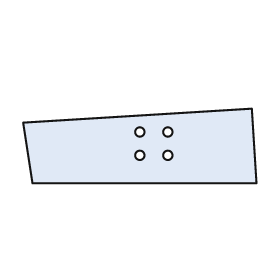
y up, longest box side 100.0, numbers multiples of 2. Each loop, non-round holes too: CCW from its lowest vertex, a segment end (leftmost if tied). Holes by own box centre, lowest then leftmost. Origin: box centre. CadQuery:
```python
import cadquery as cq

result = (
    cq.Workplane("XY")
    .moveTo(-46.0, -16.0)
    .lineTo(50.0, -16.0)
    .lineTo(48.0, 16.0)
    .lineTo(-50.0, 10.0)
    .close()
    .moveTo(0.0, -4.0)
    .circle(2.0)
    .moveTo(12.0, -4.0)
    .circle(2.0)
    .moveTo(0.0, 6.0)
    .circle(2.0)
    .moveTo(12.0, 6.0)
    .circle(2.0)
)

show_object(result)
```